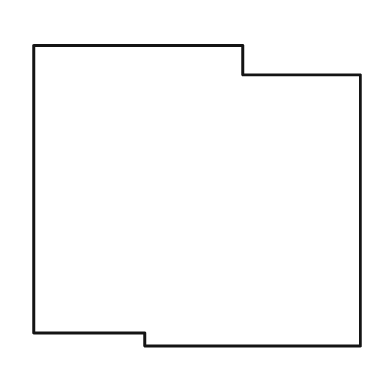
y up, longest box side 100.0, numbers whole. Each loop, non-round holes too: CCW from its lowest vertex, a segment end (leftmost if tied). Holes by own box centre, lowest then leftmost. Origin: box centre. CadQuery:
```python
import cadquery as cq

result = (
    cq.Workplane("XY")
    .moveTo(-16.0, -46.0)
    .lineTo(50.0, -46.0)
    .lineTo(50.0, 37.0)
    .lineTo(14.0, 37.0)
    .lineTo(14.0, 46.0)
    .lineTo(-50.0, 46.0)
    .lineTo(-50.0, -42.0)
    .lineTo(-16.0, -42.0)
    .close()
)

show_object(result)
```